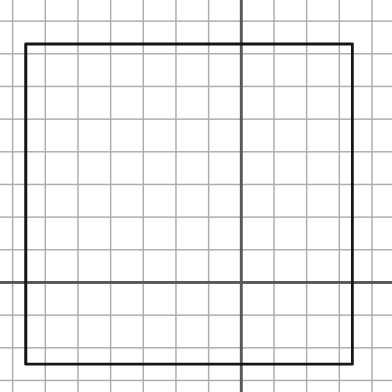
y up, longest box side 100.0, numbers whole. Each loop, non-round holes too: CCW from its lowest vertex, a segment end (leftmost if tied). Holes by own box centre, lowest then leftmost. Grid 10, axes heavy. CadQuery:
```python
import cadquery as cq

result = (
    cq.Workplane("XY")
    .moveTo(-66.0, -25.0)
    .lineTo(34.0, -25.0)
    .lineTo(34.0, 73.0)
    .lineTo(-66.0, 73.0)
    .close()
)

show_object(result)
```